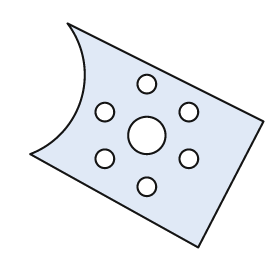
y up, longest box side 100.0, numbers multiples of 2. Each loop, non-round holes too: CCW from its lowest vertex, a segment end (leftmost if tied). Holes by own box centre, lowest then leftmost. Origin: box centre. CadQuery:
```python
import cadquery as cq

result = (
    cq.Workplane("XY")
    .moveTo(22.0, -48.0)
    .lineTo(50.0, 6.0)
    .lineTo(-34.0, 48.0)
    .threePointArc((-28.0, 16.0), (-50.0, -8.0))
    .close()
    .moveTo(0.0, -22.0)
    .circle(4.0)
    .moveTo(-18.0, -10.0)
    .circle(4.0)
    .moveTo(18.0, -10.0)
    .circle(4.0)
    .moveTo(0.0, 0.0)
    .circle(8.0)
    .moveTo(-18.0, 10.0)
    .circle(4.0)
    .moveTo(18.0, 10.0)
    .circle(4.0)
    .moveTo(0.0, 22.0)
    .circle(4.0)
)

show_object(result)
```